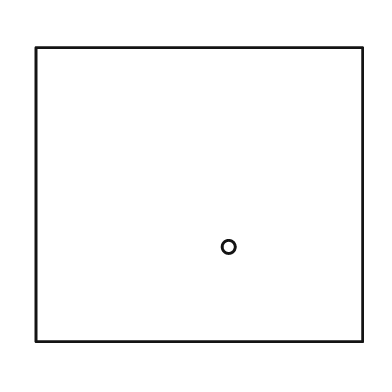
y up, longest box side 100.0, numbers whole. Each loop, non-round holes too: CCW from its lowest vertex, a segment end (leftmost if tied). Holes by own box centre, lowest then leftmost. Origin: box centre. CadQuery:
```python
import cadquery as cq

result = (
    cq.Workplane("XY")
    .moveTo(-50.0, -45.0)
    .lineTo(50.0, -45.0)
    .lineTo(50.0, 45.0)
    .lineTo(-50.0, 45.0)
    .close()
    .moveTo(9.0, -16.0)
    .circle(2.0)
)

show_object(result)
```